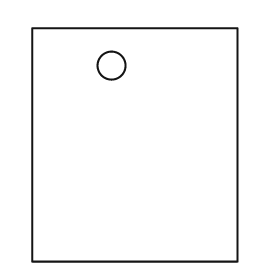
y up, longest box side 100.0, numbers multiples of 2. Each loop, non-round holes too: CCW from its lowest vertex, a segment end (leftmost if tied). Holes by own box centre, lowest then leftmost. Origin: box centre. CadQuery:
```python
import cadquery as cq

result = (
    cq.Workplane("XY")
    .moveTo(-44.0, -50.0)
    .lineTo(44.0, -50.0)
    .lineTo(44.0, 50.0)
    .lineTo(-44.0, 50.0)
    .close()
    .moveTo(-10.0, 34.0)
    .circle(6.0)
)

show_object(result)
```